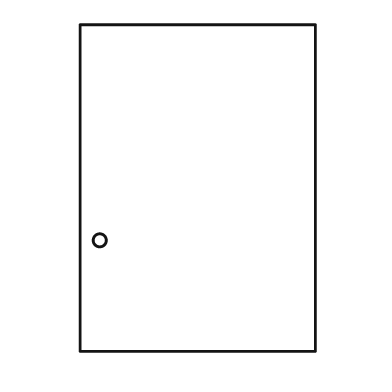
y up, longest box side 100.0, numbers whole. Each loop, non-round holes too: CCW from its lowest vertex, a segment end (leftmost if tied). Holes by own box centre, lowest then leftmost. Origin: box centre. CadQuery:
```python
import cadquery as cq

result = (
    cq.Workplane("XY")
    .moveTo(-36.0, -50.0)
    .lineTo(36.0, -50.0)
    .lineTo(36.0, 50.0)
    .lineTo(-36.0, 50.0)
    .close()
    .moveTo(-30.0, -16.0)
    .circle(2.0)
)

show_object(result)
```